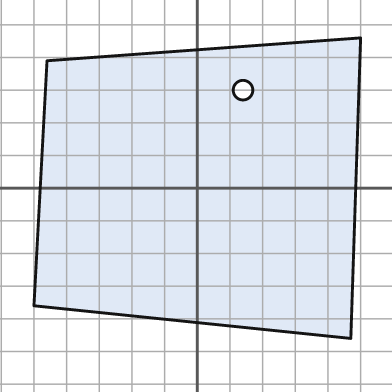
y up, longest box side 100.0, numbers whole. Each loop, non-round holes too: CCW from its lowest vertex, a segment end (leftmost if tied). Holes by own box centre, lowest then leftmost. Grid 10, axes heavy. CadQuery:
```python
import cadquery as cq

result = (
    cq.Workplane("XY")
    .moveTo(47.0, -46.0)
    .lineTo(50.0, 46.0)
    .lineTo(-46.0, 39.0)
    .lineTo(-50.0, -36.0)
    .close()
    .moveTo(14.0, 30.0)
    .circle(3.0)
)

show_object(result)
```